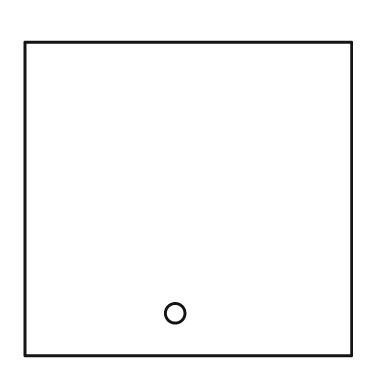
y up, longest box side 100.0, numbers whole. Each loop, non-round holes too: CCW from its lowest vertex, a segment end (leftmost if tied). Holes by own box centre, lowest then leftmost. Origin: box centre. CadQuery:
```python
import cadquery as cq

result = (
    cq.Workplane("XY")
    .moveTo(-50.0, -48.0)
    .lineTo(50.0, -48.0)
    .lineTo(50.0, 48.0)
    .lineTo(-50.0, 48.0)
    .close()
    .moveTo(-4.0, -35.0)
    .circle(3.0)
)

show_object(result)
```